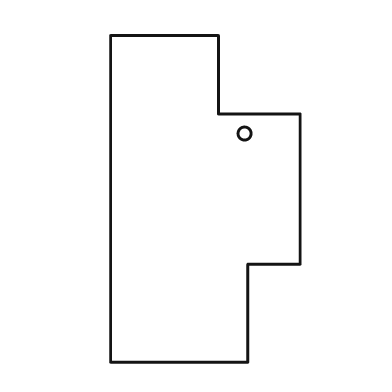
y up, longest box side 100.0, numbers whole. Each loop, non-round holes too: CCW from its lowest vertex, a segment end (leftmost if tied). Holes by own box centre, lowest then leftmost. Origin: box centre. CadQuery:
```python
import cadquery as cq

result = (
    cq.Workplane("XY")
    .moveTo(-29.0, -50.0)
    .lineTo(13.0, -50.0)
    .lineTo(13.0, -20.0)
    .lineTo(29.0, -20.0)
    .lineTo(29.0, 26.0)
    .lineTo(4.0, 26.0)
    .lineTo(4.0, 50.0)
    .lineTo(-29.0, 50.0)
    .close()
    .moveTo(12.0, 20.0)
    .circle(2.0)
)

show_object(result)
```